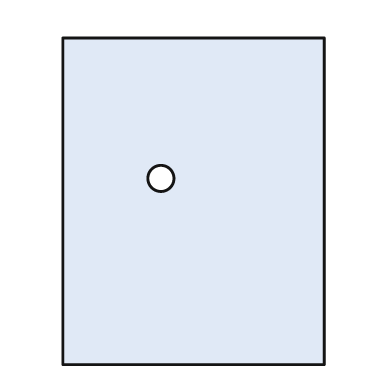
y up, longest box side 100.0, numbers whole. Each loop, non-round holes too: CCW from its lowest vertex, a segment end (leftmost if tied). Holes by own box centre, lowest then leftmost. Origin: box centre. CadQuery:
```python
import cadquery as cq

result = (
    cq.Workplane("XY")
    .moveTo(-40.0, -50.0)
    .lineTo(40.0, -50.0)
    .lineTo(40.0, 50.0)
    .lineTo(-40.0, 50.0)
    .close()
    .moveTo(-10.0, 7.0)
    .circle(4.0)
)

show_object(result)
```